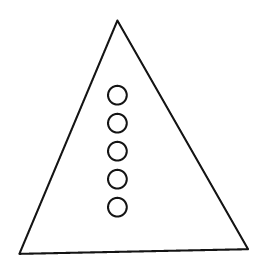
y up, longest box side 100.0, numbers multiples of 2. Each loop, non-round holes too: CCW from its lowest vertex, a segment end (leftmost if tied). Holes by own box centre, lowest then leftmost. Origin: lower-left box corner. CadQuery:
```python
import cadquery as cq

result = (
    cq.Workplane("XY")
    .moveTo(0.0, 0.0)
    .lineTo(98.0, 2.0)
    .lineTo(42.0, 100.0)
    .close()
    .moveTo(42.0, 20.0)
    .circle(4.0)
    .moveTo(42.0, 32.0)
    .circle(4.0)
    .moveTo(42.0, 44.0)
    .circle(4.0)
    .moveTo(42.0, 56.0)
    .circle(4.0)
    .moveTo(42.0, 68.0)
    .circle(4.0)
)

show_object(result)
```